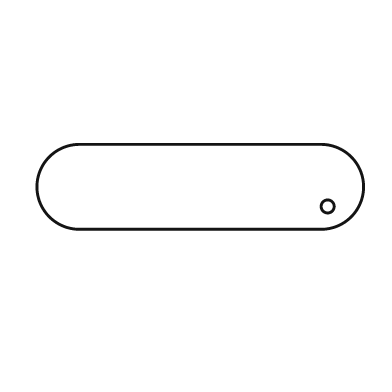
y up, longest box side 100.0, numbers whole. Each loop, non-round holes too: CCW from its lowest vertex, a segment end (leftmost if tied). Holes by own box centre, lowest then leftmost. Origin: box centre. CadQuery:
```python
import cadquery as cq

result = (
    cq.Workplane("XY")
    .moveTo(-37.0, -13.0)
    .lineTo(37.0, -13.0)
    .threePointArc((50.0, 0.0), (37.0, 13.0))
    .lineTo(-37.0, 13.0)
    .threePointArc((-50.0, 0.0), (-37.0, -13.0))
    .close()
    .moveTo(39.0, -6.0)
    .circle(2.0)
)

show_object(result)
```